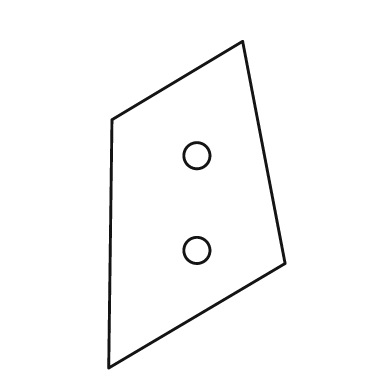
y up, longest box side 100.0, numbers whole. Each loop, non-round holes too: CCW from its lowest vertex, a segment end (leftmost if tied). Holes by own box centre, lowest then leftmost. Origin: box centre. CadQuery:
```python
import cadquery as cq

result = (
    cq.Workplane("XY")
    .moveTo(-27.0, -50.0)
    .lineTo(27.0, -18.0)
    .lineTo(14.0, 50.0)
    .lineTo(-26.0, 26.0)
    .close()
    .moveTo(0.0, -14.0)
    .circle(4.0)
    .moveTo(0.0, 15.0)
    .circle(4.0)
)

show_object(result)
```